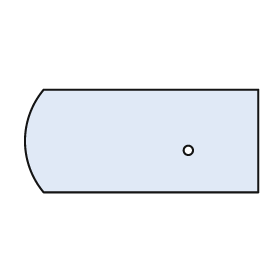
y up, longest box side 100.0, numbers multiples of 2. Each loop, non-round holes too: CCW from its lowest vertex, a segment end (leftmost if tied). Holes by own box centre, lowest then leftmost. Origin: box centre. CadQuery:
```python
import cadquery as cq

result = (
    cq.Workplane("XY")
    .moveTo(-42.0, -22.0)
    .lineTo(50.0, -22.0)
    .lineTo(50.0, 22.0)
    .lineTo(-42.0, 22.0)
    .threePointArc((-50.0, 0.0), (-42.0, -22.0))
    .close()
    .moveTo(20.0, -4.0)
    .circle(2.0)
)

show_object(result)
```